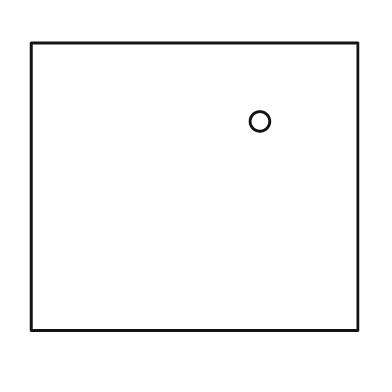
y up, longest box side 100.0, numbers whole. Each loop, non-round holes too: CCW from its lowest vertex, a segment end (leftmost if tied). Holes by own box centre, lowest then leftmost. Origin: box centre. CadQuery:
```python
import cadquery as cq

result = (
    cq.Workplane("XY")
    .moveTo(-50.0, -44.0)
    .lineTo(50.0, -44.0)
    .lineTo(50.0, 44.0)
    .lineTo(-50.0, 44.0)
    .close()
    .moveTo(20.0, 20.0)
    .circle(3.0)
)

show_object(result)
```